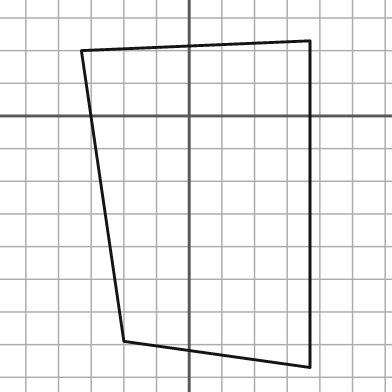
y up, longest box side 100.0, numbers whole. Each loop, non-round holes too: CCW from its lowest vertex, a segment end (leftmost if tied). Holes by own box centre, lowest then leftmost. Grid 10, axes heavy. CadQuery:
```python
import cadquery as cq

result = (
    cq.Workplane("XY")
    .moveTo(37.0, -77.0)
    .lineTo(37.0, 23.0)
    .lineTo(-33.0, 20.0)
    .lineTo(-20.0, -69.0)
    .close()
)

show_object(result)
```